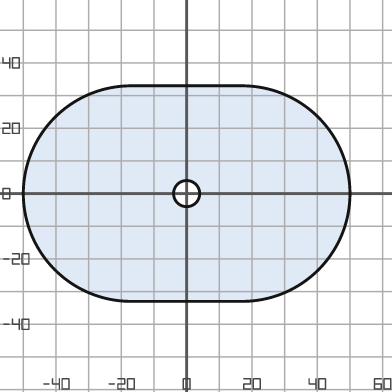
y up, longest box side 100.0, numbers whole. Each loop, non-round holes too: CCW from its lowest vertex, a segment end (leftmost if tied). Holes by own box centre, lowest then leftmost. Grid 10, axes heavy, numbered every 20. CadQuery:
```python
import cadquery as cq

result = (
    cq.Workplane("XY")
    .moveTo(-17.0, -33.0)
    .lineTo(17.0, -33.0)
    .threePointArc((50.0, 0.0), (17.0, 33.0))
    .lineTo(-17.0, 33.0)
    .threePointArc((-50.0, 0.0), (-17.0, -33.0))
    .close()
    .moveTo(0.0, 0.0)
    .circle(4.0)
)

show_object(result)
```